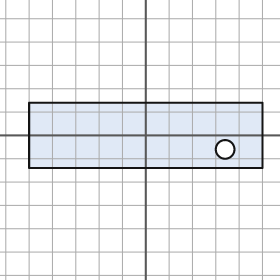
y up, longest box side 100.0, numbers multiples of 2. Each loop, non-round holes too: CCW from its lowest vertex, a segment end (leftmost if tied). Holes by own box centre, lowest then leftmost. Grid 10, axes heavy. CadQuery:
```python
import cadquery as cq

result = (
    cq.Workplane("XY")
    .moveTo(-50.0, -14.0)
    .lineTo(50.0, -14.0)
    .lineTo(50.0, 14.0)
    .lineTo(-50.0, 14.0)
    .close()
    .moveTo(34.0, -6.0)
    .circle(4.0)
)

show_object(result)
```